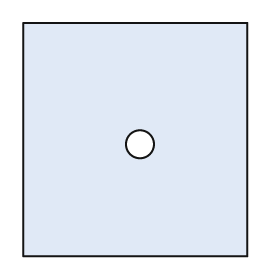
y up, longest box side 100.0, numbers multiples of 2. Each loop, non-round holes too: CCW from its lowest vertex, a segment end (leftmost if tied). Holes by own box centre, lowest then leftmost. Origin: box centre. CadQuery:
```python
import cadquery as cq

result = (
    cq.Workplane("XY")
    .moveTo(-48.0, -50.0)
    .lineTo(48.0, -50.0)
    .lineTo(48.0, 50.0)
    .lineTo(-48.0, 50.0)
    .close()
    .moveTo(2.0, -2.0)
    .circle(6.0)
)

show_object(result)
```